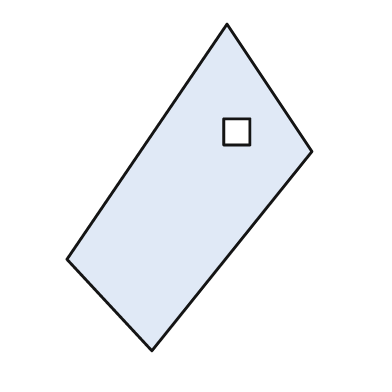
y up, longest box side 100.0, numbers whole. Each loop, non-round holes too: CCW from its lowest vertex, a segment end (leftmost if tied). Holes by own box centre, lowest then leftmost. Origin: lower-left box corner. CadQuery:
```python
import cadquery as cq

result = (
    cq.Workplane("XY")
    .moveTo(26.0, 0.0)
    .lineTo(75.0, 61.0)
    .lineTo(49.0, 100.0)
    .lineTo(0.0, 28.0)
    .close()
    .moveTo(48.0, 63.0)
    .lineTo(56.0, 63.0)
    .lineTo(56.0, 71.0)
    .lineTo(48.0, 71.0)
    .close()
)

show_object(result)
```